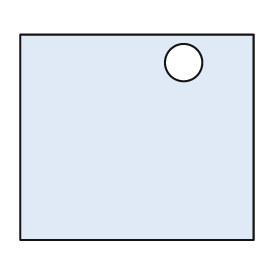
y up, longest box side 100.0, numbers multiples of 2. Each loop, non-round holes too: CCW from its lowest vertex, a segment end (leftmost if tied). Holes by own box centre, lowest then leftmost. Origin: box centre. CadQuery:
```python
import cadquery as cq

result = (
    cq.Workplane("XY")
    .moveTo(-50.0, -44.0)
    .lineTo(50.0, -44.0)
    .lineTo(50.0, 44.0)
    .lineTo(-50.0, 44.0)
    .close()
    .moveTo(20.0, 32.0)
    .circle(8.0)
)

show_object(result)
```